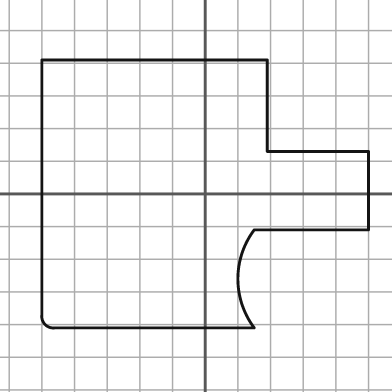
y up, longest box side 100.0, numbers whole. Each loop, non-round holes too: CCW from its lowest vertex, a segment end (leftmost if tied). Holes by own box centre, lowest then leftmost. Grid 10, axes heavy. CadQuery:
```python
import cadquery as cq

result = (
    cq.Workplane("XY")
    .moveTo(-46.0, -41.0)
    .lineTo(15.0, -41.0)
    .threePointArc((10.0, -26.0), (15.0, -11.0))
    .lineTo(50.0, -11.0)
    .lineTo(50.0, 13.0)
    .lineTo(19.0, 13.0)
    .lineTo(19.0, 41.0)
    .lineTo(-50.0, 41.0)
    .lineTo(-50.0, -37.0)
    .threePointArc((-49.0, -40.0), (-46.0, -41.0))
    .close()
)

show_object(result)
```